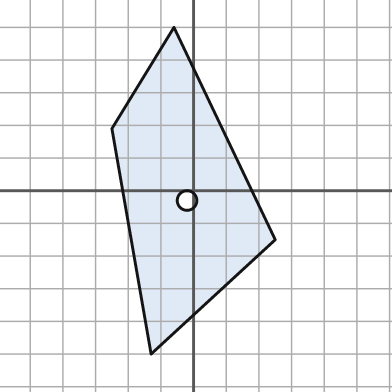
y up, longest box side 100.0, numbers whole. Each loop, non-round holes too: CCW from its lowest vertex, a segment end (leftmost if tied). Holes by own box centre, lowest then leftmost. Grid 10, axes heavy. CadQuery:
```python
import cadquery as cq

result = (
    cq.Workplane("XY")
    .moveTo(-13.0, -50.0)
    .lineTo(25.0, -15.0)
    .lineTo(-6.0, 50.0)
    .lineTo(-25.0, 19.0)
    .close()
    .moveTo(-2.0, -3.0)
    .circle(3.0)
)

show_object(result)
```